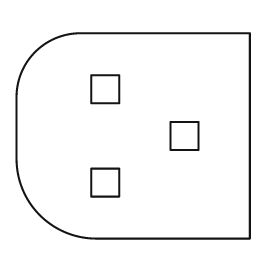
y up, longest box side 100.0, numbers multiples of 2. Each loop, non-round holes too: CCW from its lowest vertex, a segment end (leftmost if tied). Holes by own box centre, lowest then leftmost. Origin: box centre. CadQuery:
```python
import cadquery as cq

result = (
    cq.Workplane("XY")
    .moveTo(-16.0, -44.0)
    .lineTo(50.0, -44.0)
    .lineTo(50.0, 44.0)
    .lineTo(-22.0, 44.0)
    .threePointArc((-42.0, 36.0), (-50.0, 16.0))
    .lineTo(-50.0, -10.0)
    .threePointArc((-40.0, -34.0), (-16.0, -44.0))
    .close()
    .moveTo(-18.0, -26.0)
    .lineTo(-6.0, -26.0)
    .lineTo(-6.0, -14.0)
    .lineTo(-18.0, -14.0)
    .close()
    .moveTo(16.0, -6.0)
    .lineTo(28.0, -6.0)
    .lineTo(28.0, 6.0)
    .lineTo(16.0, 6.0)
    .close()
    .moveTo(-18.0, 14.0)
    .lineTo(-6.0, 14.0)
    .lineTo(-6.0, 26.0)
    .lineTo(-18.0, 26.0)
    .close()
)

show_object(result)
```